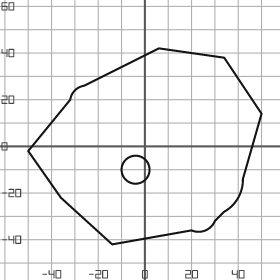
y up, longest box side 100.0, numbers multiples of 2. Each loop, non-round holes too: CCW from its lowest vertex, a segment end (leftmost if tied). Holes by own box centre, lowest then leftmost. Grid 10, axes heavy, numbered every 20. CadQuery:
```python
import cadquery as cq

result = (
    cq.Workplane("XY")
    .moveTo(-14.0, -42.0)
    .lineTo(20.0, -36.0)
    .threePointArc((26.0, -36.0), (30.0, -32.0))
    .lineTo(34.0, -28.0)
    .threePointArc((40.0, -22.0), (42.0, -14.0))
    .lineTo(50.0, 14.0)
    .lineTo(34.0, 38.0)
    .lineTo(6.0, 42.0)
    .lineTo(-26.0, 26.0)
    .threePointArc((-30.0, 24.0), (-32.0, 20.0))
    .lineTo(-50.0, -2.0)
    .lineTo(-36.0, -22.0)
    .close()
    .moveTo(-4.0, -10.0)
    .circle(6.0)
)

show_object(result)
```